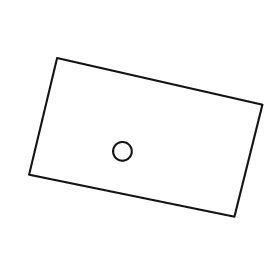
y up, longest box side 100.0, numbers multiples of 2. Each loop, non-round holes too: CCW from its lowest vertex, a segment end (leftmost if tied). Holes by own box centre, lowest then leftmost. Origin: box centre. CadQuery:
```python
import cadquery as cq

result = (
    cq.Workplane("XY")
    .moveTo(38.0, -34.0)
    .lineTo(50.0, 14.0)
    .lineTo(-38.0, 34.0)
    .lineTo(-50.0, -16.0)
    .close()
    .moveTo(-10.0, -6.0)
    .circle(4.0)
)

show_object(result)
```